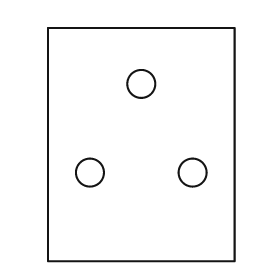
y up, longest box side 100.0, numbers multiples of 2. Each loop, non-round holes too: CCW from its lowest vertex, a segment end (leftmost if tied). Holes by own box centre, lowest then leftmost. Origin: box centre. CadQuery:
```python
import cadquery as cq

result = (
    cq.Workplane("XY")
    .moveTo(-40.0, -50.0)
    .lineTo(40.0, -50.0)
    .lineTo(40.0, 50.0)
    .lineTo(-40.0, 50.0)
    .close()
    .moveTo(-22.0, -12.0)
    .circle(6.0)
    .moveTo(22.0, -12.0)
    .circle(6.0)
    .moveTo(0.0, 26.0)
    .circle(6.0)
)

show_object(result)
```